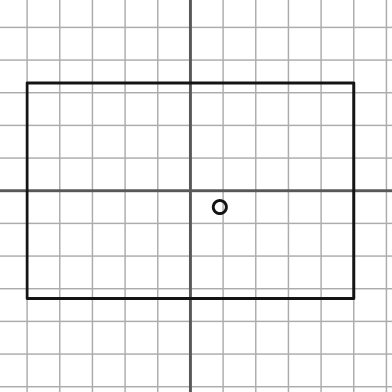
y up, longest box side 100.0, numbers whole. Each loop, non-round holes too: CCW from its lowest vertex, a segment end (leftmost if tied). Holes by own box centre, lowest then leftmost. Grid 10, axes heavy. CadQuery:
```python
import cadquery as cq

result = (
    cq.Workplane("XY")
    .moveTo(-50.0, -33.0)
    .lineTo(50.0, -33.0)
    .lineTo(50.0, 33.0)
    .lineTo(-50.0, 33.0)
    .close()
    .moveTo(9.0, -5.0)
    .circle(2.0)
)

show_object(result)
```